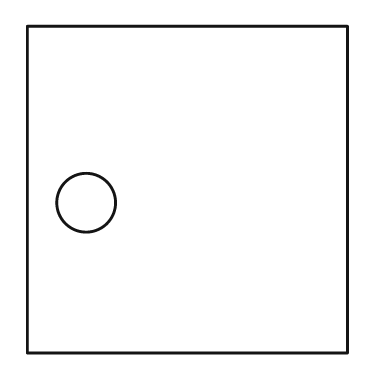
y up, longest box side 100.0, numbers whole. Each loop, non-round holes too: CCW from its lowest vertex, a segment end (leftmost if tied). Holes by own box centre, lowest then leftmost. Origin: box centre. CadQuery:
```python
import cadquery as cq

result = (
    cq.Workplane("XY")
    .moveTo(-49.0, -50.0)
    .lineTo(49.0, -50.0)
    .lineTo(49.0, 50.0)
    .lineTo(-49.0, 50.0)
    .close()
    .moveTo(-31.0, -4.0)
    .circle(9.0)
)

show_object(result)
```